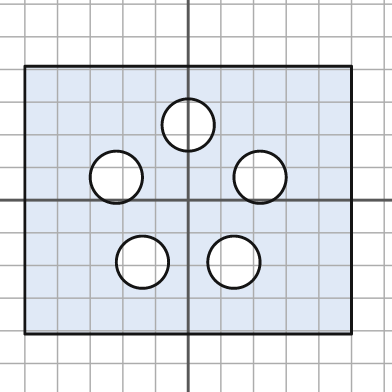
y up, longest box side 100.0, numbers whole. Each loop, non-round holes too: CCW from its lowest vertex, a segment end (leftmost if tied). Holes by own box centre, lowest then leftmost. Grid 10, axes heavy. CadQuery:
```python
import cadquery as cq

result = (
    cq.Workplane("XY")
    .moveTo(-50.0, -41.0)
    .lineTo(50.0, -41.0)
    .lineTo(50.0, 41.0)
    .lineTo(-50.0, 41.0)
    .close()
    .moveTo(-14.0, -19.0)
    .circle(8.0)
    .moveTo(14.0, -19.0)
    .circle(8.0)
    .moveTo(-22.0, 7.0)
    .circle(8.0)
    .moveTo(22.0, 7.0)
    .circle(8.0)
    .moveTo(0.0, 23.0)
    .circle(8.0)
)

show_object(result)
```